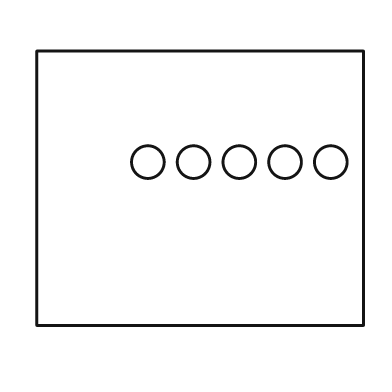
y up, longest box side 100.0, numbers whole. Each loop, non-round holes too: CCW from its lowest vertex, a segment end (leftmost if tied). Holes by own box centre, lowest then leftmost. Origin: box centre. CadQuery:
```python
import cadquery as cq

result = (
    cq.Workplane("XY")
    .moveTo(-50.0, -42.0)
    .lineTo(50.0, -42.0)
    .lineTo(50.0, 42.0)
    .lineTo(-50.0, 42.0)
    .close()
    .moveTo(-16.0, 8.0)
    .circle(5.0)
    .moveTo(-2.0, 8.0)
    .circle(5.0)
    .moveTo(12.0, 8.0)
    .circle(5.0)
    .moveTo(26.0, 8.0)
    .circle(5.0)
    .moveTo(40.0, 8.0)
    .circle(5.0)
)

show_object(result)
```